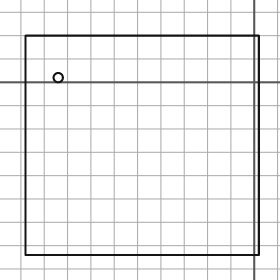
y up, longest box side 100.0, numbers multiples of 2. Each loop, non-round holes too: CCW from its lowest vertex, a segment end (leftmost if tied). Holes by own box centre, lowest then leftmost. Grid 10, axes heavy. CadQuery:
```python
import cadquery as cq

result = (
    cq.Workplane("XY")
    .moveTo(-98.0, -74.0)
    .lineTo(2.0, -74.0)
    .lineTo(2.0, 20.0)
    .lineTo(-98.0, 20.0)
    .close()
    .moveTo(-84.0, 2.0)
    .circle(2.0)
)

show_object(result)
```